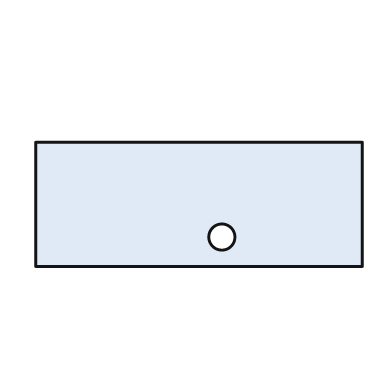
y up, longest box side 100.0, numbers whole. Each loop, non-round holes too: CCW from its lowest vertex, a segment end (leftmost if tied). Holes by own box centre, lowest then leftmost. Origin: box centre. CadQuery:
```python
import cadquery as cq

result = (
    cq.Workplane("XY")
    .moveTo(-50.0, -19.0)
    .lineTo(50.0, -19.0)
    .lineTo(50.0, 19.0)
    .lineTo(-50.0, 19.0)
    .close()
    .moveTo(7.0, -10.0)
    .circle(4.0)
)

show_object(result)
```